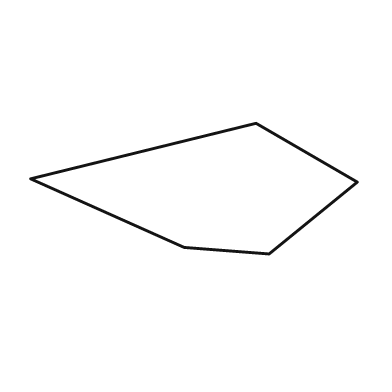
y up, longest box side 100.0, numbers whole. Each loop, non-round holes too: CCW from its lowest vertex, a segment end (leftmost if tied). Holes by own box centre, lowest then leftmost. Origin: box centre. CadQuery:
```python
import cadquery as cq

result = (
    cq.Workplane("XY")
    .moveTo(23.0, -20.0)
    .lineTo(50.0, 2.0)
    .lineTo(19.0, 20.0)
    .lineTo(-50.0, 3.0)
    .lineTo(-3.0, -18.0)
    .close()
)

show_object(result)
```